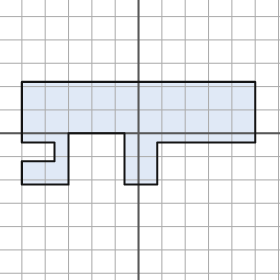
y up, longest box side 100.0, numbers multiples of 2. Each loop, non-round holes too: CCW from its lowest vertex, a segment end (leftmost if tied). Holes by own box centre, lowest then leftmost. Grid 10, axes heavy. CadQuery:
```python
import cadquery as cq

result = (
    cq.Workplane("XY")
    .moveTo(-50.0, -22.0)
    .lineTo(-30.0, -22.0)
    .lineTo(-30.0, 0.0)
    .lineTo(-6.0, 0.0)
    .lineTo(-6.0, -22.0)
    .lineTo(8.0, -22.0)
    .lineTo(8.0, -4.0)
    .lineTo(50.0, -4.0)
    .lineTo(50.0, 22.0)
    .lineTo(-50.0, 22.0)
    .lineTo(-50.0, -4.0)
    .lineTo(-36.0, -4.0)
    .lineTo(-36.0, -12.0)
    .lineTo(-50.0, -12.0)
    .close()
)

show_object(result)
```